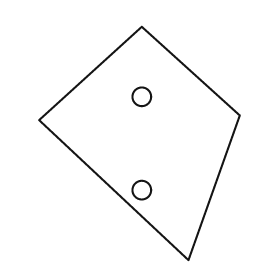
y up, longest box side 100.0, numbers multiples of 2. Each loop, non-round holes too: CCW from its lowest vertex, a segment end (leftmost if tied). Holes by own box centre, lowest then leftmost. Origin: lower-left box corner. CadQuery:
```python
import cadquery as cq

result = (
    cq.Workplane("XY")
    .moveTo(64.0, 0.0)
    .lineTo(86.0, 62.0)
    .lineTo(44.0, 100.0)
    .lineTo(0.0, 60.0)
    .close()
    .moveTo(44.0, 30.0)
    .circle(4.0)
    .moveTo(44.0, 70.0)
    .circle(4.0)
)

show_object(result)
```